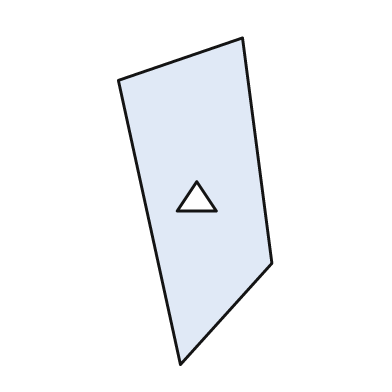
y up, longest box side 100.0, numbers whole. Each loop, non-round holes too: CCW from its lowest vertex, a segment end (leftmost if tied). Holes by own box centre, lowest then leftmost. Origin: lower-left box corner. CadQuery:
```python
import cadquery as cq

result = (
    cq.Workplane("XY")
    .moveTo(19.0, 0.0)
    .lineTo(47.0, 31.0)
    .lineTo(38.0, 100.0)
    .lineTo(0.0, 87.0)
    .close()
    .moveTo(18.0, 47.0)
    .lineTo(30.0, 47.0)
    .lineTo(24.0, 56.0)
    .close()
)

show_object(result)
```